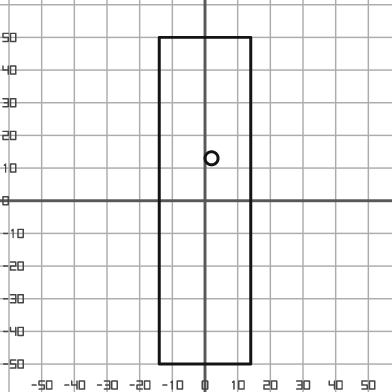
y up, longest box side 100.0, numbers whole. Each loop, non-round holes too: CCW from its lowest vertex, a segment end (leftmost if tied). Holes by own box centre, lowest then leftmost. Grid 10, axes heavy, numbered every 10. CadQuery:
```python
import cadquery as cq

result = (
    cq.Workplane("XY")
    .moveTo(-14.0, -50.0)
    .lineTo(14.0, -50.0)
    .lineTo(14.0, 50.0)
    .lineTo(-14.0, 50.0)
    .close()
    .moveTo(2.0, 13.0)
    .circle(2.0)
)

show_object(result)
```